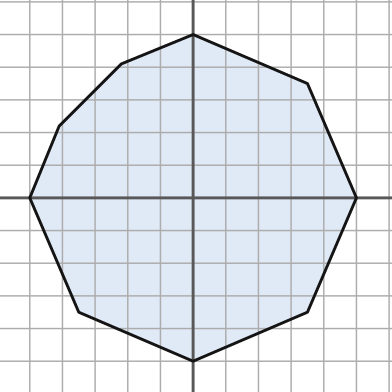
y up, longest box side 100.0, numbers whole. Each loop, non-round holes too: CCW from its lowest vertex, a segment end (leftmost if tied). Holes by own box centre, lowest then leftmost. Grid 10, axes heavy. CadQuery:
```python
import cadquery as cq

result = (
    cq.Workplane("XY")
    .moveTo(0.0, -50.0)
    .lineTo(35.0, -35.0)
    .lineTo(50.0, 0.0)
    .lineTo(35.0, 35.0)
    .lineTo(0.0, 50.0)
    .lineTo(-22.0, 41.0)
    .lineTo(-41.0, 22.0)
    .lineTo(-50.0, 0.0)
    .lineTo(-35.0, -35.0)
    .close()
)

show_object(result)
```